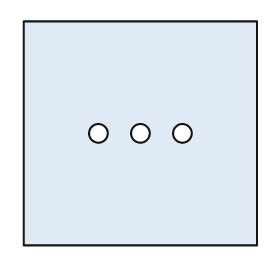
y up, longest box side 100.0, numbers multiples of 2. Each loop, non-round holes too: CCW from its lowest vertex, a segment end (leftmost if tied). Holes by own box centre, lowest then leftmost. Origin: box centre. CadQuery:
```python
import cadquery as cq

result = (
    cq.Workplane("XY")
    .moveTo(-50.0, -48.0)
    .lineTo(50.0, -48.0)
    .lineTo(50.0, 48.0)
    .lineTo(-50.0, 48.0)
    .close()
    .moveTo(-18.0, 0.0)
    .circle(4.0)
    .moveTo(0.0, 0.0)
    .circle(4.0)
    .moveTo(18.0, 0.0)
    .circle(4.0)
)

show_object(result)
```